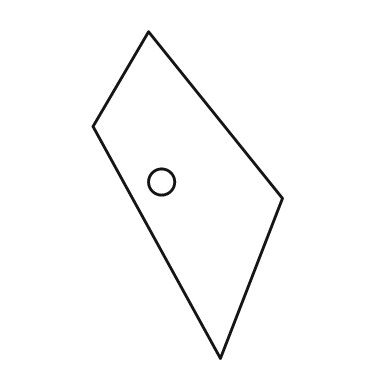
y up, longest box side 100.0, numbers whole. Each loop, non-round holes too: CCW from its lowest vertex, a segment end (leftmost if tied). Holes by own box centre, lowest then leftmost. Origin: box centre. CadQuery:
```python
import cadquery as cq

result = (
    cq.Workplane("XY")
    .moveTo(10.0, -50.0)
    .lineTo(29.0, -1.0)
    .lineTo(-12.0, 50.0)
    .lineTo(-29.0, 21.0)
    .close()
    .moveTo(-8.0, 4.0)
    .circle(4.0)
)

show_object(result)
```